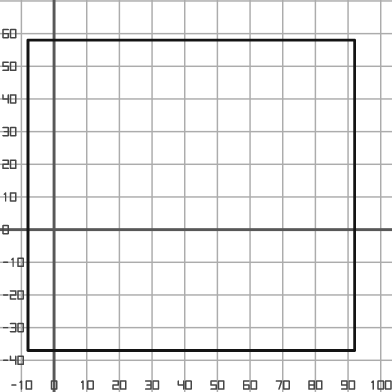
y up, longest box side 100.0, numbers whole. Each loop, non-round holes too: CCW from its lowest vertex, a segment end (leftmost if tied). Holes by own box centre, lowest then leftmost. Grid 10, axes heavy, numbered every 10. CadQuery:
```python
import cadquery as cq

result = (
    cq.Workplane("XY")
    .moveTo(-8.0, -37.0)
    .lineTo(92.0, -37.0)
    .lineTo(92.0, 58.0)
    .lineTo(-8.0, 58.0)
    .close()
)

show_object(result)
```